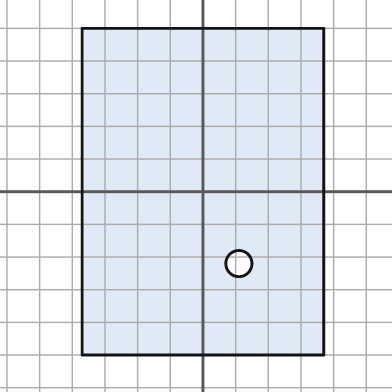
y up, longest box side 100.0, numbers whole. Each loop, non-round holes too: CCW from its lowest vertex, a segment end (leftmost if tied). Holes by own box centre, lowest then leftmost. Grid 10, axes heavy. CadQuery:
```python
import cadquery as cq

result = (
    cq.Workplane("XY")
    .moveTo(-37.0, -50.0)
    .lineTo(37.0, -50.0)
    .lineTo(37.0, 50.0)
    .lineTo(-37.0, 50.0)
    .close()
    .moveTo(11.0, -22.0)
    .circle(4.0)
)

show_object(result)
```